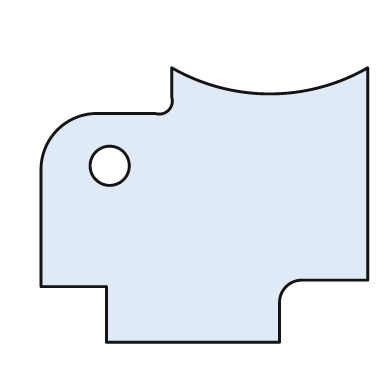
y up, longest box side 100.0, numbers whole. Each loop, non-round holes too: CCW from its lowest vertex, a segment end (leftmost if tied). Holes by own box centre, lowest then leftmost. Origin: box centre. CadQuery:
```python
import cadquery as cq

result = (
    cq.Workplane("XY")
    .moveTo(-30.0, -42.0)
    .lineTo(23.0, -42.0)
    .lineTo(23.0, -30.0)
    .threePointArc((25.0, -25.0), (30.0, -23.0))
    .lineTo(50.0, -23.0)
    .lineTo(50.0, 42.0)
    .threePointArc((20.0, 34.0), (-10.0, 42.0))
    .lineTo(-10.0, 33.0)
    .threePointArc((-11.0, 29.0), (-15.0, 28.0))
    .lineTo(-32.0, 28.0)
    .threePointArc((-45.0, 23.0), (-50.0, 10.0))
    .lineTo(-50.0, -25.0)
    .lineTo(-30.0, -25.0)
    .close()
    .moveTo(-29.0, 12.0)
    .circle(6.0)
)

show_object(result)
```